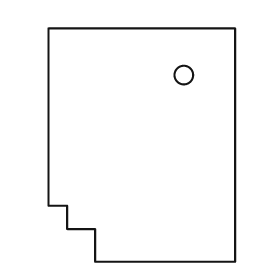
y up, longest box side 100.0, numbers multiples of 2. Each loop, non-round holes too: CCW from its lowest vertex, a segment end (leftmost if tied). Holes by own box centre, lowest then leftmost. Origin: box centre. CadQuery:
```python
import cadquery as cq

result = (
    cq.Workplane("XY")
    .moveTo(-20.0, -50.0)
    .lineTo(40.0, -50.0)
    .lineTo(40.0, 50.0)
    .lineTo(-40.0, 50.0)
    .lineTo(-40.0, -26.0)
    .lineTo(-32.0, -26.0)
    .lineTo(-32.0, -36.0)
    .lineTo(-20.0, -36.0)
    .close()
    .moveTo(18.0, 30.0)
    .circle(4.0)
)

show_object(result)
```